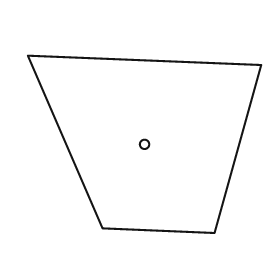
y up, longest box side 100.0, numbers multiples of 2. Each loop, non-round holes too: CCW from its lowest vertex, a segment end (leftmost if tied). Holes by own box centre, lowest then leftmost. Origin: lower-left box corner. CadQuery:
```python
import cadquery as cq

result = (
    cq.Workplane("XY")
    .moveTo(80.0, 0.0)
    .lineTo(100.0, 72.0)
    .lineTo(0.0, 76.0)
    .lineTo(32.0, 2.0)
    .close()
    .moveTo(50.0, 38.0)
    .circle(2.0)
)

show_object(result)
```